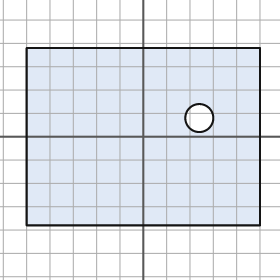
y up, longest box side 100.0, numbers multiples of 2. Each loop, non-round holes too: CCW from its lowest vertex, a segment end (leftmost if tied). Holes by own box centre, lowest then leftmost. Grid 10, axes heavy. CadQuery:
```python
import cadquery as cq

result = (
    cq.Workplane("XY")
    .moveTo(-50.0, -38.0)
    .lineTo(50.0, -38.0)
    .lineTo(50.0, 38.0)
    .lineTo(-50.0, 38.0)
    .close()
    .moveTo(24.0, 8.0)
    .circle(6.0)
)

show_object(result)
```